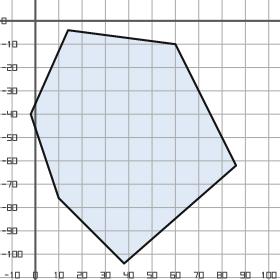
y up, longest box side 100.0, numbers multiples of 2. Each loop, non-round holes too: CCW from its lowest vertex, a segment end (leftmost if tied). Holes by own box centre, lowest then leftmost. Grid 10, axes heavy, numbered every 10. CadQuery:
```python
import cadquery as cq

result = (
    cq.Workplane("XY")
    .moveTo(38.0, -104.0)
    .lineTo(86.0, -62.0)
    .lineTo(60.0, -10.0)
    .lineTo(14.0, -4.0)
    .lineTo(-2.0, -40.0)
    .lineTo(10.0, -76.0)
    .close()
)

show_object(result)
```